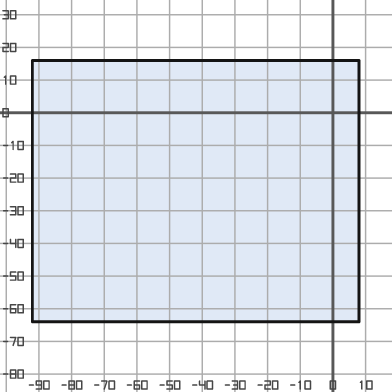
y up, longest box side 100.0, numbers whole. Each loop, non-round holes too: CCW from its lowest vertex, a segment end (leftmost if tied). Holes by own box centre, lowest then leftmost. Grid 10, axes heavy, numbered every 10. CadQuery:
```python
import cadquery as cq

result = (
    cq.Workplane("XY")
    .moveTo(-92.0, -64.0)
    .lineTo(8.0, -64.0)
    .lineTo(8.0, 16.0)
    .lineTo(-92.0, 16.0)
    .close()
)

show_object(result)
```